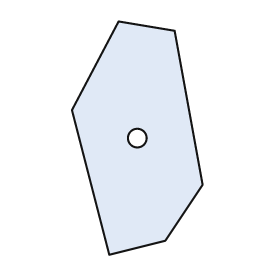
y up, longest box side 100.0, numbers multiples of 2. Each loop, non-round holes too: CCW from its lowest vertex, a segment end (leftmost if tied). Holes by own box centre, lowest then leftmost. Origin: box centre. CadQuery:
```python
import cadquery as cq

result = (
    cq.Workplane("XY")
    .moveTo(-12.0, -50.0)
    .lineTo(12.0, -44.0)
    .lineTo(28.0, -20.0)
    .lineTo(16.0, 46.0)
    .lineTo(-8.0, 50.0)
    .lineTo(-28.0, 12.0)
    .close()
    .moveTo(0.0, 0.0)
    .circle(4.0)
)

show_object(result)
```